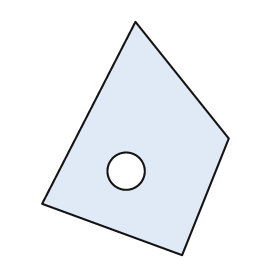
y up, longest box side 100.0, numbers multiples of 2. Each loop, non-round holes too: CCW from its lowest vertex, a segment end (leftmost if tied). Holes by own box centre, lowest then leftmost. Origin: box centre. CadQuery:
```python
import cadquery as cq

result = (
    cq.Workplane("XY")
    .moveTo(20.0, -50.0)
    .lineTo(40.0, 0.0)
    .lineTo(0.0, 50.0)
    .lineTo(-40.0, -28.0)
    .close()
    .moveTo(-4.0, -14.0)
    .circle(8.0)
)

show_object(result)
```